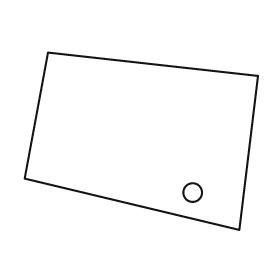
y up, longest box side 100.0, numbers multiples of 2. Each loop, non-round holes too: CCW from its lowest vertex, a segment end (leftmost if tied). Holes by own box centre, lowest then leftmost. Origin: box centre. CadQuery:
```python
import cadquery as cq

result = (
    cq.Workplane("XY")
    .moveTo(42.0, -38.0)
    .lineTo(50.0, 28.0)
    .lineTo(-40.0, 38.0)
    .lineTo(-50.0, -16.0)
    .close()
    .moveTo(22.0, -22.0)
    .circle(4.0)
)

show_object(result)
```